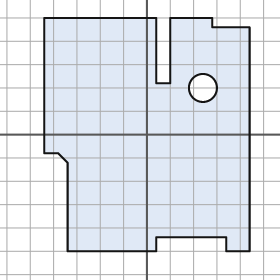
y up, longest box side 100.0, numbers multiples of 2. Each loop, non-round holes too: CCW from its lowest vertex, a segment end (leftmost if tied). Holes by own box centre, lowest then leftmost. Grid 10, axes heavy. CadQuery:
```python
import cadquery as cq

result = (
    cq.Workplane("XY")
    .moveTo(-34.0, -50.0)
    .lineTo(4.0, -50.0)
    .lineTo(4.0, -44.0)
    .lineTo(34.0, -44.0)
    .lineTo(34.0, -50.0)
    .lineTo(44.0, -50.0)
    .lineTo(44.0, 46.0)
    .lineTo(28.0, 46.0)
    .lineTo(28.0, 50.0)
    .lineTo(10.0, 50.0)
    .lineTo(10.0, 22.0)
    .lineTo(4.0, 22.0)
    .lineTo(4.0, 50.0)
    .lineTo(-44.0, 50.0)
    .lineTo(-44.0, -8.0)
    .lineTo(-38.0, -8.0)
    .lineTo(-34.0, -12.0)
    .close()
    .moveTo(24.0, 20.0)
    .circle(6.0)
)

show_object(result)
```